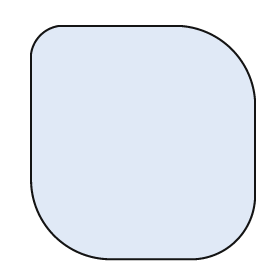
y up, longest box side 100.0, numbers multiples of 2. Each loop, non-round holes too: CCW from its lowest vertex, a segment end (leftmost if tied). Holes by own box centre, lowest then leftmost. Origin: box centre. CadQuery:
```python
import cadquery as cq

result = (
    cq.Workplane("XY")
    .moveTo(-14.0, -50.0)
    .lineTo(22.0, -50.0)
    .threePointArc((40.0, -42.0), (48.0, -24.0))
    .lineTo(48.0, 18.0)
    .threePointArc((38.0, 40.0), (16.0, 50.0))
    .lineTo(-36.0, 50.0)
    .threePointArc((-44.0, 46.0), (-48.0, 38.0))
    .lineTo(-48.0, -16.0)
    .threePointArc((-38.0, -40.0), (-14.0, -50.0))
    .close()
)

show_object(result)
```